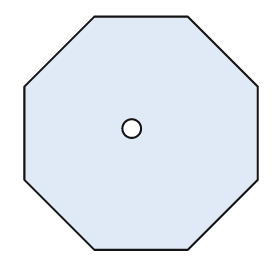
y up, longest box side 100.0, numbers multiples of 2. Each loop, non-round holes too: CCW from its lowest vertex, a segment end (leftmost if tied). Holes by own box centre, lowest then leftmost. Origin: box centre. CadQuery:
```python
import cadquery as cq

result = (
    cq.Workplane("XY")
    .moveTo(-20.0, -50.0)
    .lineTo(20.0, -50.0)
    .lineTo(50.0, -20.0)
    .lineTo(50.0, 20.0)
    .lineTo(20.0, 50.0)
    .lineTo(-20.0, 50.0)
    .lineTo(-50.0, 20.0)
    .lineTo(-50.0, -20.0)
    .close()
    .moveTo(-4.0, 2.0)
    .circle(4.0)
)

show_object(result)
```